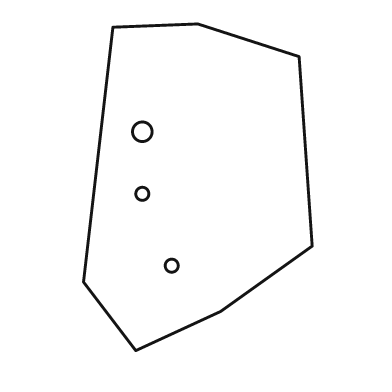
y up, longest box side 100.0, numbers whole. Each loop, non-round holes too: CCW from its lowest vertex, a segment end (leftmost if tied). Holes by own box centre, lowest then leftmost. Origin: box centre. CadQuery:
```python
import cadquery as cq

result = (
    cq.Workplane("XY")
    .moveTo(-19.0, -50.0)
    .lineTo(7.0, -38.0)
    .lineTo(35.0, -18.0)
    .lineTo(31.0, 40.0)
    .lineTo(0.0, 50.0)
    .lineTo(-26.0, 49.0)
    .lineTo(-35.0, -29.0)
    .close()
    .moveTo(-8.0, -24.0)
    .circle(2.0)
    .moveTo(-17.0, -2.0)
    .circle(2.0)
    .moveTo(-17.0, 17.0)
    .circle(3.0)
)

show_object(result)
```